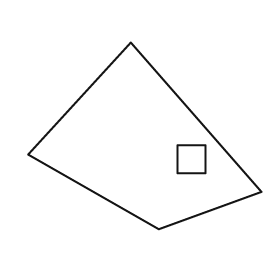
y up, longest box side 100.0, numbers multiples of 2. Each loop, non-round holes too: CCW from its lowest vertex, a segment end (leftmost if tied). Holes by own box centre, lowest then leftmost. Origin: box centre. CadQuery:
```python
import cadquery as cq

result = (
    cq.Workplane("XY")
    .moveTo(6.0, -40.0)
    .lineTo(50.0, -24.0)
    .lineTo(-6.0, 40.0)
    .lineTo(-50.0, -8.0)
    .close()
    .moveTo(14.0, -16.0)
    .lineTo(26.0, -16.0)
    .lineTo(26.0, -4.0)
    .lineTo(14.0, -4.0)
    .close()
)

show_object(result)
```